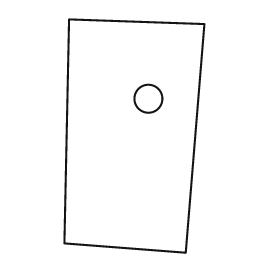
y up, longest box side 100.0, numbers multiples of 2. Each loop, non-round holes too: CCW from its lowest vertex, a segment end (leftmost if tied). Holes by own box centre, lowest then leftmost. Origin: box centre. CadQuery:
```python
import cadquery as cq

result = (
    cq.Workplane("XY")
    .moveTo(22.0, -50.0)
    .lineTo(30.0, 48.0)
    .lineTo(-28.0, 50.0)
    .lineTo(-30.0, -46.0)
    .close()
    .moveTo(6.0, 16.0)
    .circle(6.0)
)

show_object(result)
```